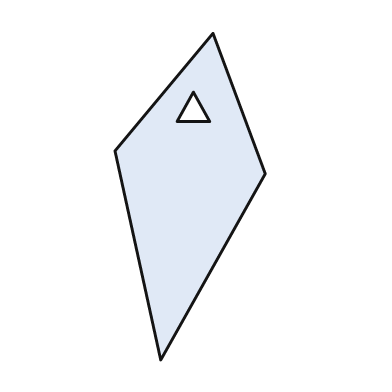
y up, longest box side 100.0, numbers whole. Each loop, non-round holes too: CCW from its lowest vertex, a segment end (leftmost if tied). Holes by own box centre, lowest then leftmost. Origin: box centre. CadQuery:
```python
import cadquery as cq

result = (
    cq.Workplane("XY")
    .moveTo(-9.0, -50.0)
    .lineTo(23.0, 7.0)
    .lineTo(7.0, 50.0)
    .lineTo(-23.0, 14.0)
    .close()
    .moveTo(-4.0, 23.0)
    .lineTo(6.0, 23.0)
    .lineTo(1.0, 32.0)
    .close()
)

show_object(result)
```